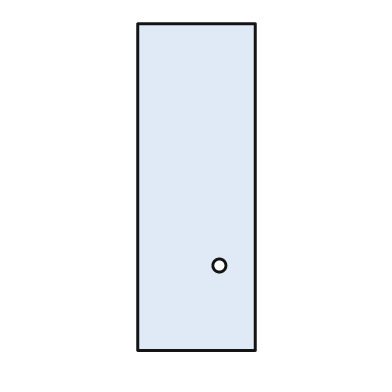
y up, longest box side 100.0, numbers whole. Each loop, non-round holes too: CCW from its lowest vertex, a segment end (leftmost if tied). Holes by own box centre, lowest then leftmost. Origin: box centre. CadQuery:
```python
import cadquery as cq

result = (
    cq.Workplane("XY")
    .moveTo(-18.0, -50.0)
    .lineTo(18.0, -50.0)
    .lineTo(18.0, 50.0)
    .lineTo(-18.0, 50.0)
    .close()
    .moveTo(7.0, -24.0)
    .circle(2.0)
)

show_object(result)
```